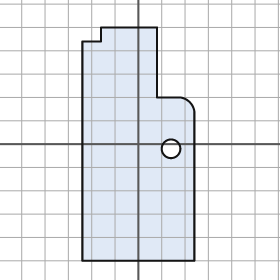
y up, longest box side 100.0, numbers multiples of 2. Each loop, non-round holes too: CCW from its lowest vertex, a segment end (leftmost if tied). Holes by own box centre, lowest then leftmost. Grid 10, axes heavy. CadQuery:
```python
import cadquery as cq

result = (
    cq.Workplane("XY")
    .moveTo(-24.0, -50.0)
    .lineTo(24.0, -50.0)
    .lineTo(24.0, 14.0)
    .threePointArc((22.0, 18.0), (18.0, 20.0))
    .lineTo(8.0, 20.0)
    .lineTo(8.0, 50.0)
    .lineTo(-16.0, 50.0)
    .lineTo(-16.0, 44.0)
    .lineTo(-24.0, 44.0)
    .close()
    .moveTo(14.0, -2.0)
    .circle(4.0)
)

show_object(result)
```